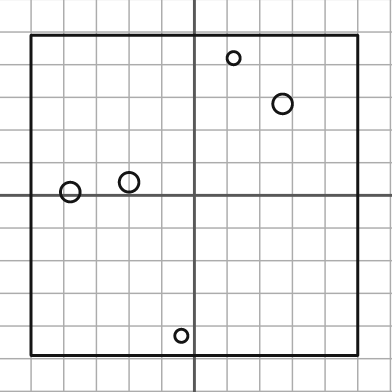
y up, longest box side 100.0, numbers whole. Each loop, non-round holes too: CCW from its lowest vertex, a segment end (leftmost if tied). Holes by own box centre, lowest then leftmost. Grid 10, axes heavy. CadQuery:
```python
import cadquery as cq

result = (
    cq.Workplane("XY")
    .moveTo(-50.0, -49.0)
    .lineTo(50.0, -49.0)
    .lineTo(50.0, 49.0)
    .lineTo(-50.0, 49.0)
    .close()
    .moveTo(-4.0, -43.0)
    .circle(2.0)
    .moveTo(-38.0, 1.0)
    .circle(3.0)
    .moveTo(-20.0, 4.0)
    .circle(3.0)
    .moveTo(27.0, 28.0)
    .circle(3.0)
    .moveTo(12.0, 42.0)
    .circle(2.0)
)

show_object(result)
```